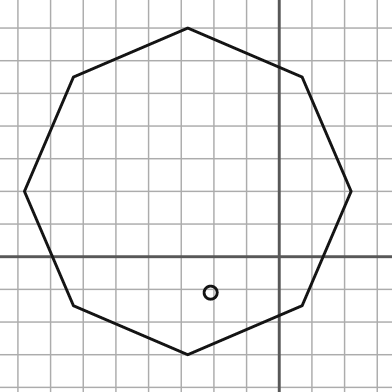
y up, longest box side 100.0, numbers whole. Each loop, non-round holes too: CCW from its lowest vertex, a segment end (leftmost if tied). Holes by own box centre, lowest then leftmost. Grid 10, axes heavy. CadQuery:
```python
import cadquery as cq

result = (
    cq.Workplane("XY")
    .moveTo(-28.0, -30.0)
    .lineTo(7.0, -15.0)
    .lineTo(22.0, 20.0)
    .lineTo(7.0, 55.0)
    .lineTo(-28.0, 70.0)
    .lineTo(-63.0, 55.0)
    .lineTo(-78.0, 20.0)
    .lineTo(-63.0, -15.0)
    .close()
    .moveTo(-21.0, -11.0)
    .circle(2.0)
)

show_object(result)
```